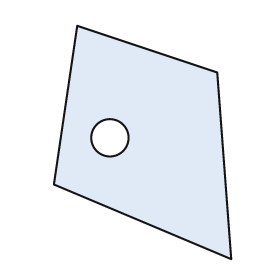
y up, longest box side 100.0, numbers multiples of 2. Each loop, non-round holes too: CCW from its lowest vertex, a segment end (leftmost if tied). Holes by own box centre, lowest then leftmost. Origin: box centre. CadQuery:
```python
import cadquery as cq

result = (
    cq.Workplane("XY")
    .moveTo(38.0, -50.0)
    .lineTo(32.0, 30.0)
    .lineTo(-28.0, 50.0)
    .lineTo(-38.0, -18.0)
    .close()
    .moveTo(-14.0, 2.0)
    .circle(8.0)
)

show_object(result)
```